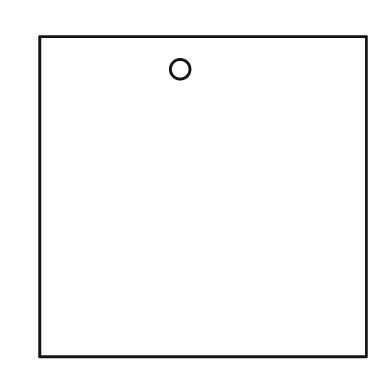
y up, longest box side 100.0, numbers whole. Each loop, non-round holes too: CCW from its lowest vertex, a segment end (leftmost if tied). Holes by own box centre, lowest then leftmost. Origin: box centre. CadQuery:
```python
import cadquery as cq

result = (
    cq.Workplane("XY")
    .moveTo(-50.0, -49.0)
    .lineTo(50.0, -49.0)
    .lineTo(50.0, 49.0)
    .lineTo(-50.0, 49.0)
    .close()
    .moveTo(-7.0, 39.0)
    .circle(3.0)
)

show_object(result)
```